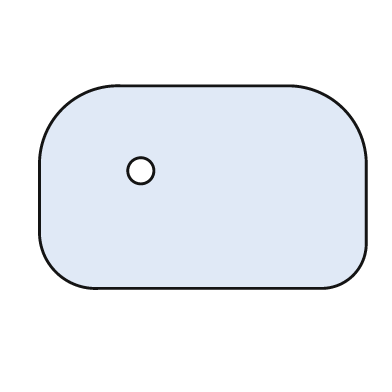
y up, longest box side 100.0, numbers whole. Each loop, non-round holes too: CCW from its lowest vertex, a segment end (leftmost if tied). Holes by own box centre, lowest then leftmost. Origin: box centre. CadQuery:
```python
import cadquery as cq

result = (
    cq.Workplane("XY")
    .moveTo(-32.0, -31.0)
    .lineTo(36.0, -31.0)
    .threePointArc((46.0, -27.0), (50.0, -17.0))
    .lineTo(50.0, 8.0)
    .threePointArc((43.0, 24.0), (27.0, 31.0))
    .lineTo(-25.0, 31.0)
    .threePointArc((-43.0, 24.0), (-50.0, 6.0))
    .lineTo(-50.0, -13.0)
    .threePointArc((-45.0, -26.0), (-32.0, -31.0))
    .close()
    .moveTo(-19.0, 5.0)
    .circle(4.0)
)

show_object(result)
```